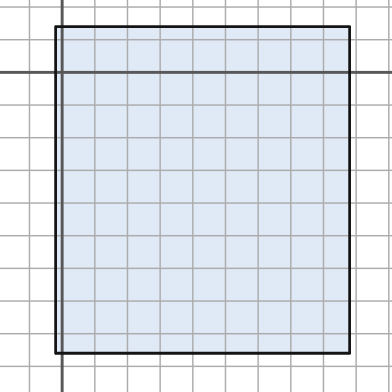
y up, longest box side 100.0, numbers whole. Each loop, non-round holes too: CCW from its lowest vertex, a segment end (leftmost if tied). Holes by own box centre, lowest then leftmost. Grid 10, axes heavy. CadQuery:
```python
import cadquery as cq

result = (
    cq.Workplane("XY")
    .moveTo(-2.0, -86.0)
    .lineTo(88.0, -86.0)
    .lineTo(88.0, 14.0)
    .lineTo(-2.0, 14.0)
    .close()
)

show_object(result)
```